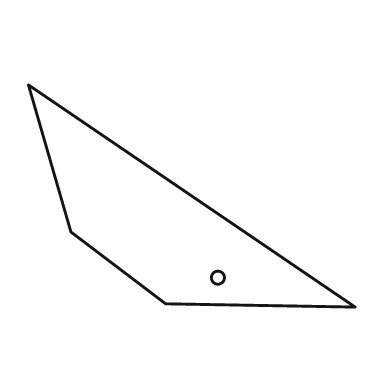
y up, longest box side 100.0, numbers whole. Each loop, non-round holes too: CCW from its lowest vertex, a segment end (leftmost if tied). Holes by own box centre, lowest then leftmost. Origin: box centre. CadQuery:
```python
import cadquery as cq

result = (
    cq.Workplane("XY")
    .moveTo(50.0, -34.0)
    .lineTo(-50.0, 34.0)
    .lineTo(-37.0, -11.0)
    .lineTo(-8.0, -33.0)
    .close()
    .moveTo(8.0, -25.0)
    .circle(2.0)
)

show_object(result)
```